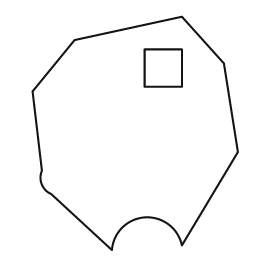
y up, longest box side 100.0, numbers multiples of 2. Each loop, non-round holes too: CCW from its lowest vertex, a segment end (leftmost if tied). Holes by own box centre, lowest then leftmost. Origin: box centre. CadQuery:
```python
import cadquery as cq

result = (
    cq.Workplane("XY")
    .moveTo(-10.0, -50.0)
    .threePointArc((4.0, -36.0), (20.0, -48.0))
    .lineTo(44.0, -8.0)
    .lineTo(38.0, 30.0)
    .lineTo(20.0, 50.0)
    .lineTo(-26.0, 40.0)
    .lineTo(-44.0, 18.0)
    .lineTo(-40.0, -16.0)
    .threePointArc((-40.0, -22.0), (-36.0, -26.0))
    .close()
    .moveTo(4.0, 20.0)
    .lineTo(20.0, 20.0)
    .lineTo(20.0, 36.0)
    .lineTo(4.0, 36.0)
    .close()
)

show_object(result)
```